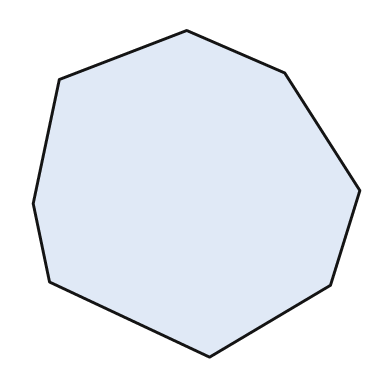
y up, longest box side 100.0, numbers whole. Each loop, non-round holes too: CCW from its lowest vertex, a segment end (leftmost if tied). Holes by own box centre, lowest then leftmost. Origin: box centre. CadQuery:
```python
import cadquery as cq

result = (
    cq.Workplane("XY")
    .moveTo(4.0, -50.0)
    .lineTo(41.0, -28.0)
    .lineTo(50.0, 1.0)
    .lineTo(27.0, 37.0)
    .lineTo(-3.0, 50.0)
    .lineTo(-42.0, 35.0)
    .lineTo(-50.0, -3.0)
    .lineTo(-45.0, -27.0)
    .close()
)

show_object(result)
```